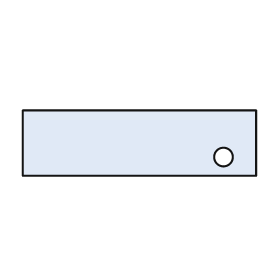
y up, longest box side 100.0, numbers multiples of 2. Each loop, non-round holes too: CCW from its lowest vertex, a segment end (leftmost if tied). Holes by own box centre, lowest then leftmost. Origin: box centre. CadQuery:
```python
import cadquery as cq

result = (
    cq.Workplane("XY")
    .moveTo(-50.0, -14.0)
    .lineTo(50.0, -14.0)
    .lineTo(50.0, 14.0)
    .lineTo(-50.0, 14.0)
    .close()
    .moveTo(36.0, -6.0)
    .circle(4.0)
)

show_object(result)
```